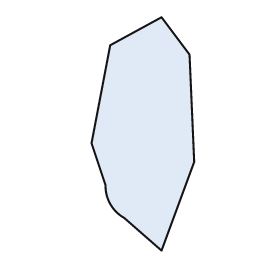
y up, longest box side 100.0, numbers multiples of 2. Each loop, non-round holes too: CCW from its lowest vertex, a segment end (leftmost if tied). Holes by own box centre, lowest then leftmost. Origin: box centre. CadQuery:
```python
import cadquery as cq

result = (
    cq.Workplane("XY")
    .moveTo(8.0, -50.0)
    .lineTo(22.0, -12.0)
    .lineTo(20.0, 34.0)
    .lineTo(8.0, 50.0)
    .lineTo(-14.0, 38.0)
    .lineTo(-22.0, -4.0)
    .lineTo(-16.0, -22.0)
    .threePointArc((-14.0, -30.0), (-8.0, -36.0))
    .close()
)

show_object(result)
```